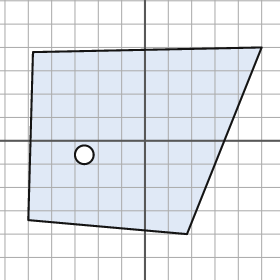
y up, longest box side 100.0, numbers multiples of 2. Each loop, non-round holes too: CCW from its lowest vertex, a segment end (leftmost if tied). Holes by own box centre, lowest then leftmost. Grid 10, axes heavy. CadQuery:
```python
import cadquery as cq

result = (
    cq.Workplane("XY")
    .moveTo(18.0, -40.0)
    .lineTo(50.0, 40.0)
    .lineTo(-48.0, 38.0)
    .lineTo(-50.0, -34.0)
    .close()
    .moveTo(-26.0, -6.0)
    .circle(4.0)
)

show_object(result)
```